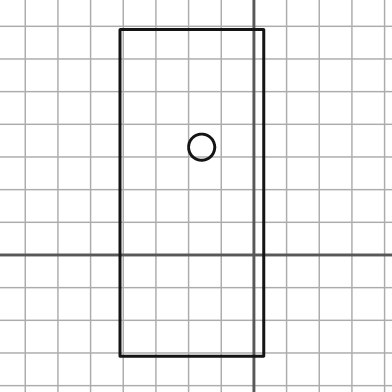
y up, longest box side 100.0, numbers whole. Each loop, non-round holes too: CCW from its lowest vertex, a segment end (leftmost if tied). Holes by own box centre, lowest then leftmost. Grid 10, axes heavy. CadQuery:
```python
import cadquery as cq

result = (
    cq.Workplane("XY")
    .moveTo(-41.0, -31.0)
    .lineTo(3.0, -31.0)
    .lineTo(3.0, 69.0)
    .lineTo(-41.0, 69.0)
    .close()
    .moveTo(-16.0, 33.0)
    .circle(4.0)
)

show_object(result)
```